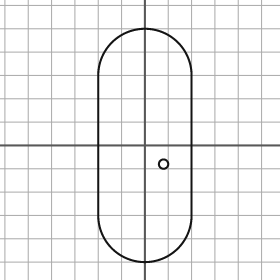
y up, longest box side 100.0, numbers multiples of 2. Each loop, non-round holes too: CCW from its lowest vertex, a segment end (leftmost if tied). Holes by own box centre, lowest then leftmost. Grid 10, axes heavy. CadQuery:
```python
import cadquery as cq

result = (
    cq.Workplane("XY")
    .moveTo(-20.0, -30.0)
    .threePointArc((0.0, -50.0), (20.0, -30.0))
    .lineTo(20.0, 30.0)
    .threePointArc((0.0, 50.0), (-20.0, 30.0))
    .close()
    .moveTo(8.0, -8.0)
    .circle(2.0)
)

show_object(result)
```